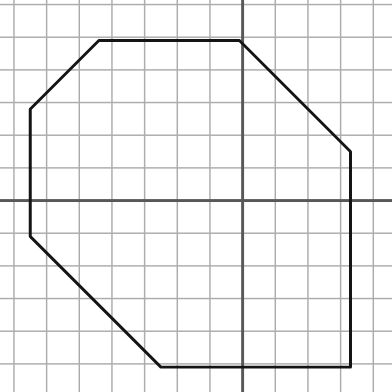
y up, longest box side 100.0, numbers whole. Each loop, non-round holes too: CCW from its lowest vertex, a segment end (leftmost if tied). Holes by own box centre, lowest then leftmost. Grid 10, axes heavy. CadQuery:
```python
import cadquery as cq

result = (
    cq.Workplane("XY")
    .moveTo(-25.0, -51.0)
    .lineTo(33.0, -51.0)
    .lineTo(33.0, 15.0)
    .lineTo(-1.0, 49.0)
    .lineTo(-44.0, 49.0)
    .lineTo(-65.0, 28.0)
    .lineTo(-65.0, -11.0)
    .close()
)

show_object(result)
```